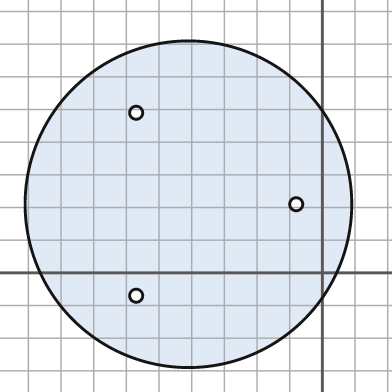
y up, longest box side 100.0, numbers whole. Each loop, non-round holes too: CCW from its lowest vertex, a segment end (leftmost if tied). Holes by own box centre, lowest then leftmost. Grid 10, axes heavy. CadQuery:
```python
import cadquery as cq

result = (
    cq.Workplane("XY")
    .moveTo(-41.0, 21.0)
    .circle(50.0)
    .moveTo(-57.0, -7.0)
    .circle(2.0)
    .moveTo(-8.0, 21.0)
    .circle(2.0)
    .moveTo(-57.0, 49.0)
    .circle(2.0)
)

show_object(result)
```